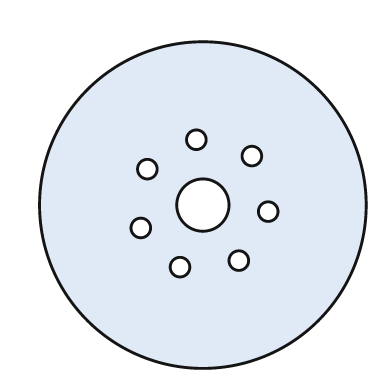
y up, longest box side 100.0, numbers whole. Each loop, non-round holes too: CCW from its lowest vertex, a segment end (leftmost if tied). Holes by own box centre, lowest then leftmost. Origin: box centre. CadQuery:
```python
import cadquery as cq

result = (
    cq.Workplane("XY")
    .moveTo(0.0, 0.0)
    .circle(50.0)
    .moveTo(-7.0, -19.0)
    .circle(3.0)
    .moveTo(11.0, -17.0)
    .circle(3.0)
    .moveTo(-19.0, -7.0)
    .circle(3.0)
    .moveTo(20.0, -2.0)
    .circle(3.0)
    .moveTo(0.0, 0.0)
    .circle(8.0)
    .moveTo(-17.0, 11.0)
    .circle(3.0)
    .moveTo(15.0, 15.0)
    .circle(3.0)
    .moveTo(-2.0, 20.0)
    .circle(3.0)
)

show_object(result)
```